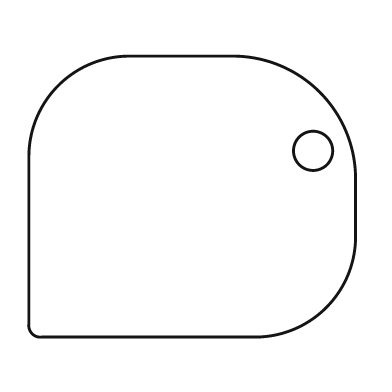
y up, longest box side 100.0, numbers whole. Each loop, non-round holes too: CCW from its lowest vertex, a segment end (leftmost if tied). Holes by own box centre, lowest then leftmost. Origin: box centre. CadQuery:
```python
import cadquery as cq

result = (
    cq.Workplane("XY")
    .moveTo(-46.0, -43.0)
    .lineTo(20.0, -43.0)
    .threePointArc((41.0, -34.0), (50.0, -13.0))
    .lineTo(50.0, 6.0)
    .threePointArc((39.0, 32.0), (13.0, 43.0))
    .lineTo(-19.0, 43.0)
    .threePointArc((-41.0, 34.0), (-50.0, 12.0))
    .lineTo(-50.0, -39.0)
    .threePointArc((-49.0, -42.0), (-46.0, -43.0))
    .close()
    .moveTo(37.0, 14.0)
    .circle(6.0)
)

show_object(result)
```